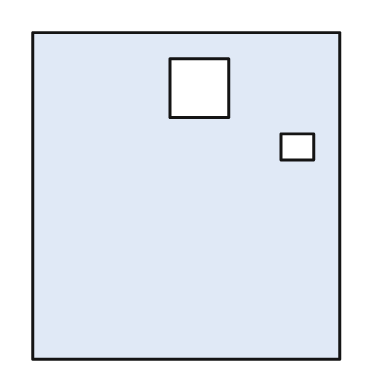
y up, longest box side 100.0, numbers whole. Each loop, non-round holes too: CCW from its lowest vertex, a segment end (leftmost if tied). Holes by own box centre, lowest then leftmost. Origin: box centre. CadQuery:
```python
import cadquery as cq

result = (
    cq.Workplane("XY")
    .moveTo(-47.0, -50.0)
    .lineTo(47.0, -50.0)
    .lineTo(47.0, 50.0)
    .lineTo(-47.0, 50.0)
    .close()
    .moveTo(29.0, 11.0)
    .lineTo(39.0, 11.0)
    .lineTo(39.0, 19.0)
    .lineTo(29.0, 19.0)
    .close()
    .moveTo(-5.0, 24.0)
    .lineTo(13.0, 24.0)
    .lineTo(13.0, 42.0)
    .lineTo(-5.0, 42.0)
    .close()
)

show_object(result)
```